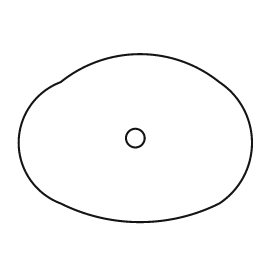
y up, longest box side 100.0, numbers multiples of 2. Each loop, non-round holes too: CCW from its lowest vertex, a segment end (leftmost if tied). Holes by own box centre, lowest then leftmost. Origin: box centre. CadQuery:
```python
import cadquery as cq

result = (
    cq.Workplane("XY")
    .moveTo(-32.0, -28.0)
    .threePointArc((2.0, -36.0), (36.0, -28.0))
    .threePointArc((50.0, -2.0), (36.0, 24.0))
    .threePointArc((2.0, 36.0), (-32.0, 24.0))
    .threePointArc((-50.0, -2.0), (-32.0, -28.0))
    .close()
    .moveTo(0.0, 0.0)
    .circle(4.0)
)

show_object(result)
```